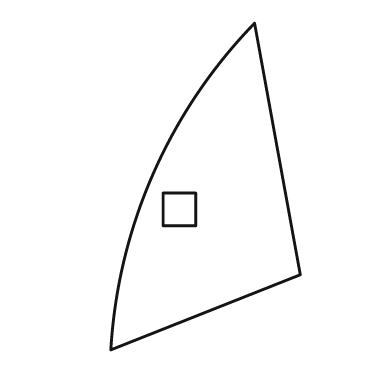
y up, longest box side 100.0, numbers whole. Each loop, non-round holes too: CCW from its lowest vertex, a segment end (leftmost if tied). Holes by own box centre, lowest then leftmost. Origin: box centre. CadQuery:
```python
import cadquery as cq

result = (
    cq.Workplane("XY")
    .moveTo(-29.0, -50.0)
    .lineTo(29.0, -27.0)
    .lineTo(15.0, 50.0)
    .threePointArc((-16.0, 4.0), (-29.0, -50.0))
    .close()
    .moveTo(-13.0, -12.0)
    .lineTo(-3.0, -12.0)
    .lineTo(-3.0, -2.0)
    .lineTo(-13.0, -2.0)
    .close()
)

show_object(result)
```